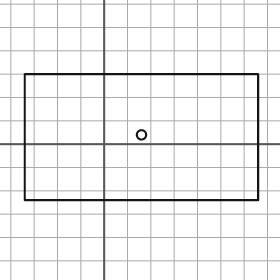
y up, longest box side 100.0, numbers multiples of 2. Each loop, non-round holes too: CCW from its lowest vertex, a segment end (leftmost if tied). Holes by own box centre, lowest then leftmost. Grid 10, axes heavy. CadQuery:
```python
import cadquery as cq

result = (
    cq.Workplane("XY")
    .moveTo(-34.0, -24.0)
    .lineTo(66.0, -24.0)
    .lineTo(66.0, 30.0)
    .lineTo(-34.0, 30.0)
    .close()
    .moveTo(16.0, 4.0)
    .circle(2.0)
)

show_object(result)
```